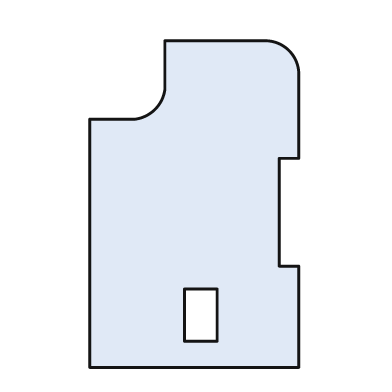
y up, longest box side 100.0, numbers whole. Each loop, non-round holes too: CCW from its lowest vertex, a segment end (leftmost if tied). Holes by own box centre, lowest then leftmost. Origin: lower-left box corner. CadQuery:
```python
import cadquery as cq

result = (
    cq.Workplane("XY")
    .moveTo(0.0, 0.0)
    .lineTo(64.0, 0.0)
    .lineTo(64.0, 31.0)
    .lineTo(58.0, 31.0)
    .lineTo(58.0, 64.0)
    .lineTo(64.0, 64.0)
    .lineTo(64.0, 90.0)
    .threePointArc((61.0, 97.0), (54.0, 100.0))
    .lineTo(23.0, 100.0)
    .lineTo(23.0, 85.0)
    .threePointArc((20.0, 79.0), (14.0, 76.0))
    .lineTo(0.0, 76.0)
    .close()
    .moveTo(29.0, 8.0)
    .lineTo(39.0, 8.0)
    .lineTo(39.0, 24.0)
    .lineTo(29.0, 24.0)
    .close()
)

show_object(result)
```